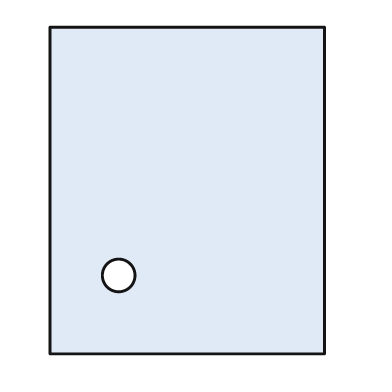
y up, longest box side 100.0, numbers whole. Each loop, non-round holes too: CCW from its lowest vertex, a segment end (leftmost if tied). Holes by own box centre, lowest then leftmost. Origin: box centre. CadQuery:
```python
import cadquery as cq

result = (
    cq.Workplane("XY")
    .moveTo(-42.0, -50.0)
    .lineTo(42.0, -50.0)
    .lineTo(42.0, 50.0)
    .lineTo(-42.0, 50.0)
    .close()
    .moveTo(-21.0, -26.0)
    .circle(5.0)
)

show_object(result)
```